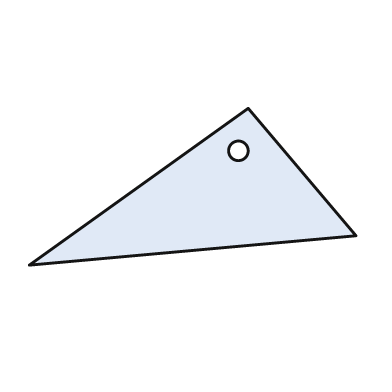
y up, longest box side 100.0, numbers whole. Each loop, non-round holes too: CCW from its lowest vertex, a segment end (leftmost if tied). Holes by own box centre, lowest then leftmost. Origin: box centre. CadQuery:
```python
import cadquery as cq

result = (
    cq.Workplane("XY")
    .moveTo(-50.0, -24.0)
    .lineTo(50.0, -15.0)
    .lineTo(17.0, 24.0)
    .close()
    .moveTo(14.0, 11.0)
    .circle(3.0)
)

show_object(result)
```